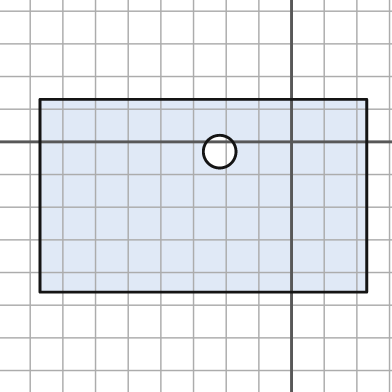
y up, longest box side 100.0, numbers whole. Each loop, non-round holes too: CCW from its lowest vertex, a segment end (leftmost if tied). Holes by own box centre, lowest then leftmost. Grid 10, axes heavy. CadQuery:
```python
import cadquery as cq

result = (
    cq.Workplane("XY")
    .moveTo(-77.0, -46.0)
    .lineTo(23.0, -46.0)
    .lineTo(23.0, 13.0)
    .lineTo(-77.0, 13.0)
    .close()
    .moveTo(-22.0, -3.0)
    .circle(5.0)
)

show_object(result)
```